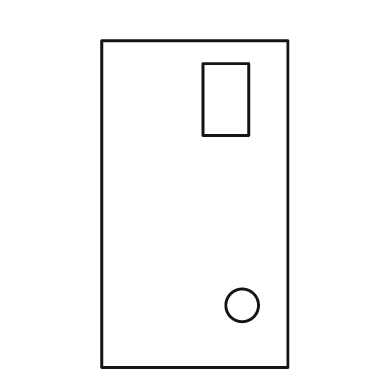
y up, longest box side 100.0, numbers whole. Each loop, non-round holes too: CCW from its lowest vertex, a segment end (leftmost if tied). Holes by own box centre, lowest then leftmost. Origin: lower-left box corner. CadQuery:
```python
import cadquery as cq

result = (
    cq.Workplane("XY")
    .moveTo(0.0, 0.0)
    .lineTo(57.0, 0.0)
    .lineTo(57.0, 100.0)
    .lineTo(0.0, 100.0)
    .close()
    .moveTo(43.0, 19.0)
    .circle(5.0)
    .moveTo(31.0, 71.0)
    .lineTo(45.0, 71.0)
    .lineTo(45.0, 93.0)
    .lineTo(31.0, 93.0)
    .close()
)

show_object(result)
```